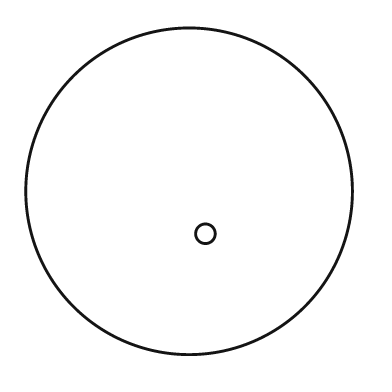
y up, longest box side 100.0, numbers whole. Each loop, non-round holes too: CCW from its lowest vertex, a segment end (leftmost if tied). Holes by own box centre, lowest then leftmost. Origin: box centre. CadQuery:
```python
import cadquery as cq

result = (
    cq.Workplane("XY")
    .moveTo(0.0, 0.0)
    .circle(50.0)
    .moveTo(5.0, -13.0)
    .circle(3.0)
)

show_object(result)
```